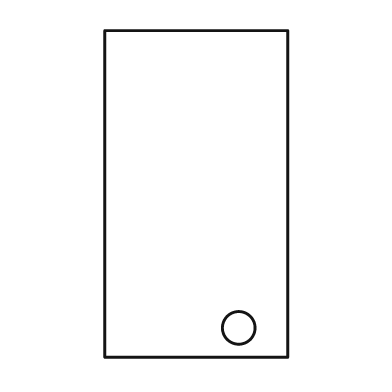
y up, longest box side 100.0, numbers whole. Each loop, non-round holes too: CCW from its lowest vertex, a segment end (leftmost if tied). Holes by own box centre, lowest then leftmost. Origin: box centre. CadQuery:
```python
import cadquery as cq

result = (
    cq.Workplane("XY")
    .moveTo(-28.0, -50.0)
    .lineTo(28.0, -50.0)
    .lineTo(28.0, 50.0)
    .lineTo(-28.0, 50.0)
    .close()
    .moveTo(13.0, -41.0)
    .circle(5.0)
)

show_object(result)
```